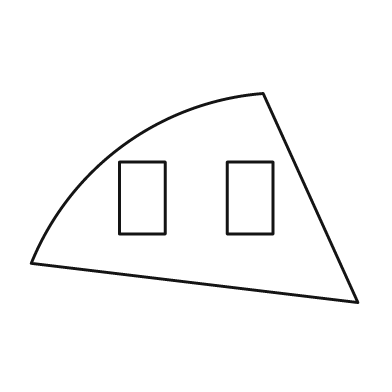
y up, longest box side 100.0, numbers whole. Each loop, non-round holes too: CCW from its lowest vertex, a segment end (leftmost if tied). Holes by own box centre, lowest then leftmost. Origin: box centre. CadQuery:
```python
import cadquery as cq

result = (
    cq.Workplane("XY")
    .moveTo(50.0, -32.0)
    .lineTo(21.0, 32.0)
    .threePointArc((-22.0, 16.0), (-50.0, -20.0))
    .close()
    .moveTo(-23.0, -11.0)
    .lineTo(-9.0, -11.0)
    .lineTo(-9.0, 11.0)
    .lineTo(-23.0, 11.0)
    .close()
    .moveTo(10.0, -11.0)
    .lineTo(24.0, -11.0)
    .lineTo(24.0, 11.0)
    .lineTo(10.0, 11.0)
    .close()
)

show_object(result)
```